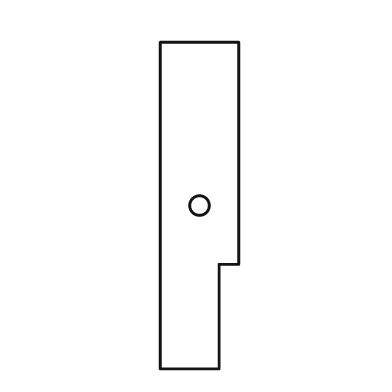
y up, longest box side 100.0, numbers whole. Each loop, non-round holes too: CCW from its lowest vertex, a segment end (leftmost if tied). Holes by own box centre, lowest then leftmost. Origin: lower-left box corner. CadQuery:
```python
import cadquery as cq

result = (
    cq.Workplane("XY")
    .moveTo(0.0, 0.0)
    .lineTo(18.0, 0.0)
    .lineTo(18.0, 32.0)
    .lineTo(24.0, 32.0)
    .lineTo(24.0, 100.0)
    .lineTo(0.0, 100.0)
    .close()
    .moveTo(12.0, 50.0)
    .circle(3.0)
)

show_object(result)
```